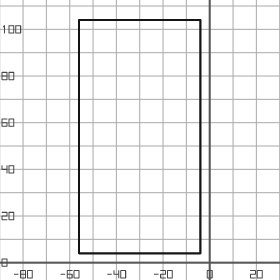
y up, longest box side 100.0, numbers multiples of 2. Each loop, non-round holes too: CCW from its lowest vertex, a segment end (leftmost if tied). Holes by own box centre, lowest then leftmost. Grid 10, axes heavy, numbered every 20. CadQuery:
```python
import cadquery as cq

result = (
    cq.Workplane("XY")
    .moveTo(-56.0, 4.0)
    .lineTo(-4.0, 4.0)
    .lineTo(-4.0, 104.0)
    .lineTo(-56.0, 104.0)
    .close()
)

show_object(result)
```